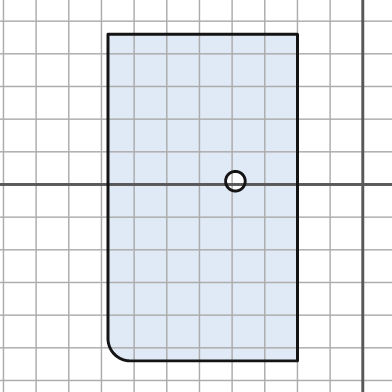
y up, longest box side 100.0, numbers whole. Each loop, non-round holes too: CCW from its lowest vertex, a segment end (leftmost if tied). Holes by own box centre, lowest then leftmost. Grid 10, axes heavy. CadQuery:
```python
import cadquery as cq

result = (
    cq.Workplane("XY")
    .moveTo(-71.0, -54.0)
    .lineTo(-20.0, -54.0)
    .lineTo(-20.0, 46.0)
    .lineTo(-78.0, 46.0)
    .lineTo(-78.0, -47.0)
    .threePointArc((-76.0, -52.0), (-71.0, -54.0))
    .close()
    .moveTo(-39.0, 1.0)
    .circle(3.0)
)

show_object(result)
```